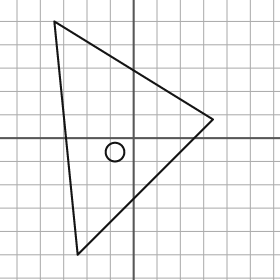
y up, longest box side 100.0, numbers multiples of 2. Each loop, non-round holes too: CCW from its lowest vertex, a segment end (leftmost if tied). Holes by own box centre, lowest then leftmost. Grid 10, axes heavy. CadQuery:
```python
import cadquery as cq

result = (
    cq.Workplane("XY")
    .moveTo(-24.0, -50.0)
    .lineTo(34.0, 8.0)
    .lineTo(-34.0, 50.0)
    .close()
    .moveTo(-8.0, -6.0)
    .circle(4.0)
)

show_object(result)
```